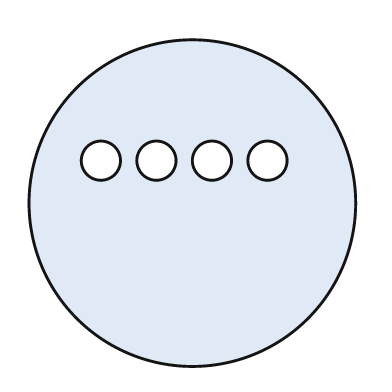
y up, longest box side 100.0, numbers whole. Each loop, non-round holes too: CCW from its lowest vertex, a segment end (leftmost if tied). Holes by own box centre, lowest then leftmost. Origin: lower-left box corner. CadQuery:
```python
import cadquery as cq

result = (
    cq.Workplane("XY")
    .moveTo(50.0, 50.0)
    .circle(50.0)
    .moveTo(22.0, 63.0)
    .circle(6.0)
    .moveTo(39.0, 63.0)
    .circle(6.0)
    .moveTo(56.0, 63.0)
    .circle(6.0)
    .moveTo(73.0, 63.0)
    .circle(6.0)
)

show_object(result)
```